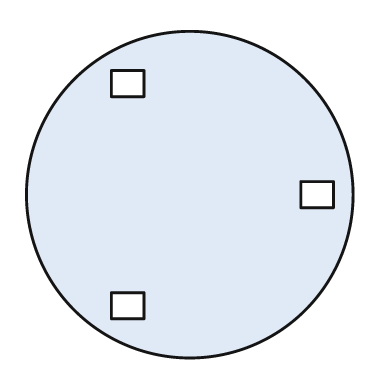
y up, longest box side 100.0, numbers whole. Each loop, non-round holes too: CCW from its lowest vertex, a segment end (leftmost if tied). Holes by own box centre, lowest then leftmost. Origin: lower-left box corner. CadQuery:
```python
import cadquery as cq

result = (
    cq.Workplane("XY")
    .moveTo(50.0, 50.0)
    .circle(50.0)
    .moveTo(26.0, 12.0)
    .lineTo(36.0, 12.0)
    .lineTo(36.0, 20.0)
    .lineTo(26.0, 20.0)
    .close()
    .moveTo(84.0, 46.0)
    .lineTo(94.0, 46.0)
    .lineTo(94.0, 54.0)
    .lineTo(84.0, 54.0)
    .close()
    .moveTo(26.0, 80.0)
    .lineTo(36.0, 80.0)
    .lineTo(36.0, 88.0)
    .lineTo(26.0, 88.0)
    .close()
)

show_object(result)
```